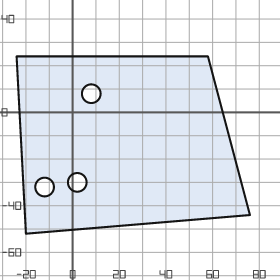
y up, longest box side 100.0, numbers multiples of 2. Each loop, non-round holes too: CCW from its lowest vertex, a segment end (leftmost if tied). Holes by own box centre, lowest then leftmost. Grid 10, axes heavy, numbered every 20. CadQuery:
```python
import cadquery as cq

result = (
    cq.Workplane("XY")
    .moveTo(-20.0, -52.0)
    .lineTo(76.0, -44.0)
    .lineTo(58.0, 24.0)
    .lineTo(-24.0, 24.0)
    .close()
    .moveTo(-12.0, -32.0)
    .circle(4.0)
    .moveTo(2.0, -30.0)
    .circle(4.0)
    .moveTo(8.0, 8.0)
    .circle(4.0)
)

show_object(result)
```